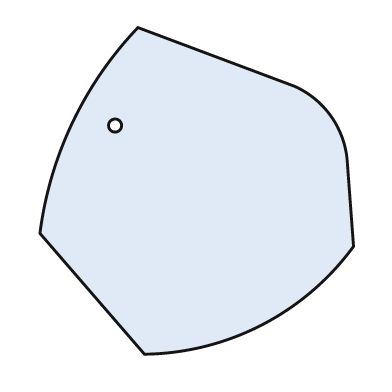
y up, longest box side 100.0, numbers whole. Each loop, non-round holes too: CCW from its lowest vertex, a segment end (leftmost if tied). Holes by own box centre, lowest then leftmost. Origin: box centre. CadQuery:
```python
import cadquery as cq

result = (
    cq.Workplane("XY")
    .moveTo(-16.0, -50.0)
    .threePointArc((20.0, -41.0), (48.0, -17.0))
    .lineTo(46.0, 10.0)
    .threePointArc((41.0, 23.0), (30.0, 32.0))
    .lineTo(-18.0, 50.0)
    .threePointArc((-38.0, 21.0), (-48.0, -13.0))
    .close()
    .moveTo(-25.0, 20.0)
    .circle(2.0)
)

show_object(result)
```